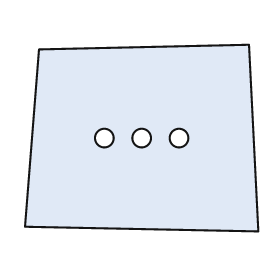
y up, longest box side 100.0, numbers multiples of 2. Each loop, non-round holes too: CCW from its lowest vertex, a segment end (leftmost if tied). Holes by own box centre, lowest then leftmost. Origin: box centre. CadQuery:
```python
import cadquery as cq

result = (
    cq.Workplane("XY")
    .moveTo(50.0, -40.0)
    .lineTo(46.0, 40.0)
    .lineTo(-44.0, 38.0)
    .lineTo(-50.0, -38.0)
    .close()
    .moveTo(-16.0, 0.0)
    .circle(4.0)
    .moveTo(0.0, 0.0)
    .circle(4.0)
    .moveTo(16.0, 0.0)
    .circle(4.0)
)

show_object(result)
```